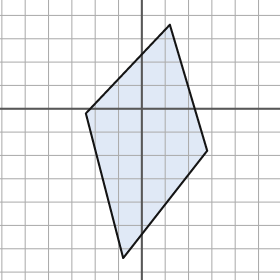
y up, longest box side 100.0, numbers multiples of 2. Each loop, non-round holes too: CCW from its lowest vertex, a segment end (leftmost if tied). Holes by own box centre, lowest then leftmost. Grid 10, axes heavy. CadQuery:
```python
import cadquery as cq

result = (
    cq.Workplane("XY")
    .moveTo(-8.0, -64.0)
    .lineTo(28.0, -18.0)
    .lineTo(12.0, 36.0)
    .lineTo(-24.0, -2.0)
    .close()
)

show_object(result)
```